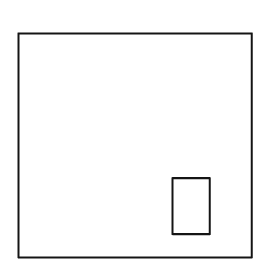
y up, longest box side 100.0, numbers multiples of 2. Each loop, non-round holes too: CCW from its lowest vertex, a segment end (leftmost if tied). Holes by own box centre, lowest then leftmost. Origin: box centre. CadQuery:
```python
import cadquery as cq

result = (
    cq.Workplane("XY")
    .moveTo(-50.0, -48.0)
    .lineTo(50.0, -48.0)
    .lineTo(50.0, 48.0)
    .lineTo(-50.0, 48.0)
    .close()
    .moveTo(16.0, -38.0)
    .lineTo(32.0, -38.0)
    .lineTo(32.0, -14.0)
    .lineTo(16.0, -14.0)
    .close()
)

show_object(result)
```